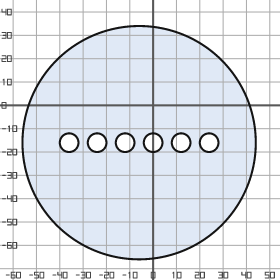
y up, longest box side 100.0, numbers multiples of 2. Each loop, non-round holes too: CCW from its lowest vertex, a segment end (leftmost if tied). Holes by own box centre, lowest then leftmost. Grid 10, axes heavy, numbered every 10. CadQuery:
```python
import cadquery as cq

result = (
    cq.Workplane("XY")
    .moveTo(-6.0, -16.0)
    .circle(50.0)
    .moveTo(-36.0, -16.0)
    .circle(4.0)
    .moveTo(-24.0, -16.0)
    .circle(4.0)
    .moveTo(-12.0, -16.0)
    .circle(4.0)
    .moveTo(0.0, -16.0)
    .circle(4.0)
    .moveTo(12.0, -16.0)
    .circle(4.0)
    .moveTo(24.0, -16.0)
    .circle(4.0)
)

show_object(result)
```